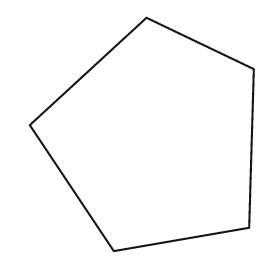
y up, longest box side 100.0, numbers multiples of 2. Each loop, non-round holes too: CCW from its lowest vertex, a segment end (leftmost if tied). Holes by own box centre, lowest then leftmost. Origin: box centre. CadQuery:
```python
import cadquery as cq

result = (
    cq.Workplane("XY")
    .moveTo(-12.0, -50.0)
    .lineTo(46.0, -40.0)
    .lineTo(48.0, 28.0)
    .lineTo(2.0, 50.0)
    .lineTo(-48.0, 4.0)
    .close()
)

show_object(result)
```